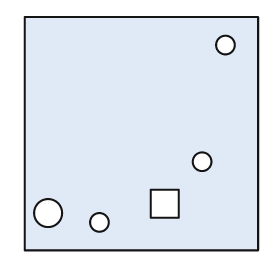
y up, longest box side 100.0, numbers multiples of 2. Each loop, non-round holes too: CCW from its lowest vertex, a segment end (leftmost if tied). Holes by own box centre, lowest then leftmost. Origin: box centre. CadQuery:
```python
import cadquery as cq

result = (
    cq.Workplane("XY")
    .moveTo(-50.0, -50.0)
    .lineTo(50.0, -50.0)
    .lineTo(50.0, 50.0)
    .lineTo(-50.0, 50.0)
    .close()
    .moveTo(-18.0, -38.0)
    .circle(4.0)
    .moveTo(-40.0, -34.0)
    .circle(6.0)
    .moveTo(4.0, -36.0)
    .lineTo(16.0, -36.0)
    .lineTo(16.0, -24.0)
    .lineTo(4.0, -24.0)
    .close()
    .moveTo(26.0, -12.0)
    .circle(4.0)
    .moveTo(36.0, 38.0)
    .circle(4.0)
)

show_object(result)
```